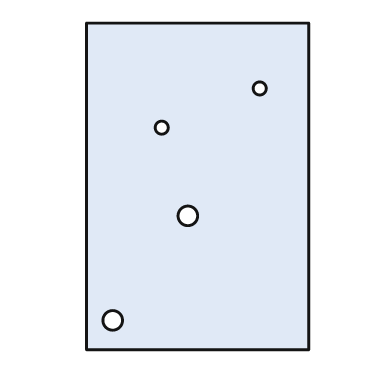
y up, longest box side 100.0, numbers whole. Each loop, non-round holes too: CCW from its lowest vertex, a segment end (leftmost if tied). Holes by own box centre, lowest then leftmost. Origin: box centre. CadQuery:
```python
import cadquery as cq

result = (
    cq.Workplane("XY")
    .moveTo(-34.0, -50.0)
    .lineTo(34.0, -50.0)
    .lineTo(34.0, 50.0)
    .lineTo(-34.0, 50.0)
    .close()
    .moveTo(-26.0, -41.0)
    .circle(3.0)
    .moveTo(-3.0, -9.0)
    .circle(3.0)
    .moveTo(-11.0, 18.0)
    .circle(2.0)
    .moveTo(19.0, 30.0)
    .circle(2.0)
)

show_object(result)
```